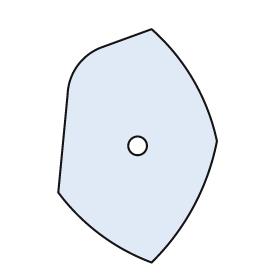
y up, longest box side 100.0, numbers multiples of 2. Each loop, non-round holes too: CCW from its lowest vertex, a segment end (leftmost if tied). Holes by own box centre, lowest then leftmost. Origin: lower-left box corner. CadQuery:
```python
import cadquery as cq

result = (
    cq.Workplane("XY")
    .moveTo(40.0, 0.0)
    .threePointArc((58.0, 24.0), (68.0, 52.0))
    .threePointArc((58.0, 78.0), (40.0, 100.0))
    .lineTo(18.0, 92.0)
    .threePointArc((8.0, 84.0), (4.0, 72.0))
    .lineTo(0.0, 30.0)
    .threePointArc((18.0, 12.0), (40.0, 0.0))
    .close()
    .moveTo(34.0, 50.0)
    .circle(4.0)
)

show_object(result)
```